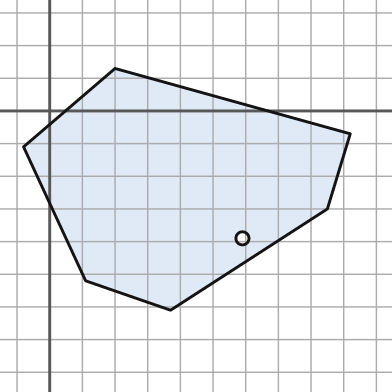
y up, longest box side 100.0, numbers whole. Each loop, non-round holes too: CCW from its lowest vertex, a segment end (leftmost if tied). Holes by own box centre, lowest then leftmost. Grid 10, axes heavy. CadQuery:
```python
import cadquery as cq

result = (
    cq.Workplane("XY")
    .moveTo(37.0, -61.0)
    .lineTo(85.0, -30.0)
    .lineTo(92.0, -7.0)
    .lineTo(20.0, 13.0)
    .lineTo(-8.0, -11.0)
    .lineTo(11.0, -52.0)
    .close()
    .moveTo(59.0, -39.0)
    .circle(2.0)
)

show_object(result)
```